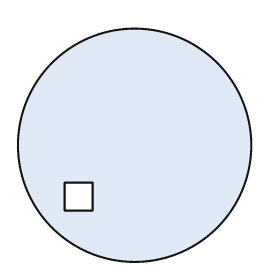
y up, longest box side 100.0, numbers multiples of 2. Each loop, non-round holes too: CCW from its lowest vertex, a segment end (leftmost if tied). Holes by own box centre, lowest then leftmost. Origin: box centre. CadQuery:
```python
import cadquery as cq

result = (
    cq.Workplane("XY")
    .moveTo(0.0, 0.0)
    .circle(50.0)
    .moveTo(-30.0, -28.0)
    .lineTo(-18.0, -28.0)
    .lineTo(-18.0, -16.0)
    .lineTo(-30.0, -16.0)
    .close()
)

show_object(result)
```